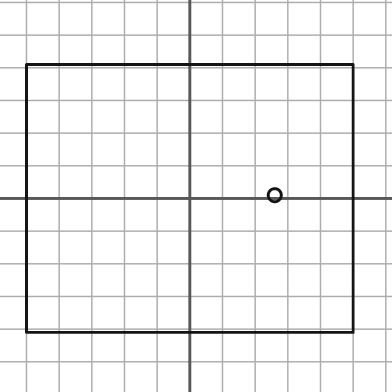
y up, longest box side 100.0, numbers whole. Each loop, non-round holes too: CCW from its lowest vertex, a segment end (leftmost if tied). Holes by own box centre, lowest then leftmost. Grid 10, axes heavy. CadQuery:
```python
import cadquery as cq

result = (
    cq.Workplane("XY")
    .moveTo(-50.0, -41.0)
    .lineTo(50.0, -41.0)
    .lineTo(50.0, 41.0)
    .lineTo(-50.0, 41.0)
    .close()
    .moveTo(26.0, 1.0)
    .circle(2.0)
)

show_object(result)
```